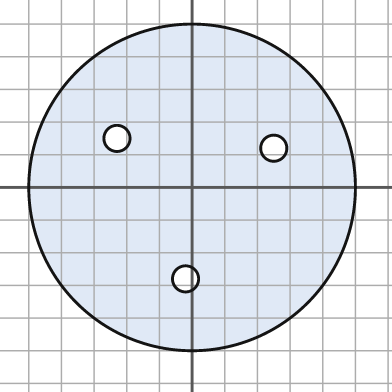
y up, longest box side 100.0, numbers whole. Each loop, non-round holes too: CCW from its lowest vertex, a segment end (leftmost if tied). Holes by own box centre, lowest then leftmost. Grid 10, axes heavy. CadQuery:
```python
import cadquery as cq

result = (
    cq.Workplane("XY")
    .moveTo(0.0, 0.0)
    .circle(50.0)
    .moveTo(-2.0, -28.0)
    .circle(4.0)
    .moveTo(25.0, 12.0)
    .circle(4.0)
    .moveTo(-23.0, 15.0)
    .circle(4.0)
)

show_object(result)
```